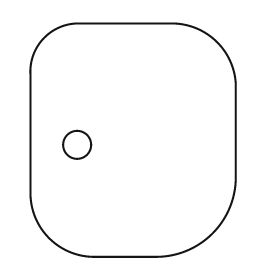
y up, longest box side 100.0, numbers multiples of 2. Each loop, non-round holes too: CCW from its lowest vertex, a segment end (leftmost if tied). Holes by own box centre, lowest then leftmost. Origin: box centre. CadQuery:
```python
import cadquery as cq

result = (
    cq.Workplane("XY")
    .moveTo(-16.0, -50.0)
    .lineTo(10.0, -50.0)
    .threePointArc((34.0, -40.0), (44.0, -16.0))
    .lineTo(44.0, 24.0)
    .threePointArc((36.0, 42.0), (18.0, 50.0))
    .lineTo(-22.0, 50.0)
    .threePointArc((-38.0, 44.0), (-44.0, 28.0))
    .lineTo(-44.0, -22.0)
    .threePointArc((-36.0, -42.0), (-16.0, -50.0))
    .close()
    .moveTo(-24.0, -2.0)
    .circle(6.0)
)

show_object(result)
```